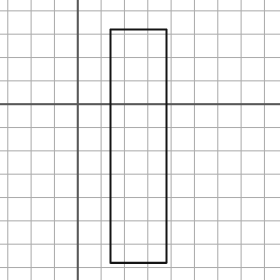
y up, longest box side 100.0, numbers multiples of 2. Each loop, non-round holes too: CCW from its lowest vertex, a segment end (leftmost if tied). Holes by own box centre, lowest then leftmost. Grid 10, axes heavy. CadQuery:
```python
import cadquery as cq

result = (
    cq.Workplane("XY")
    .moveTo(14.0, -68.0)
    .lineTo(38.0, -68.0)
    .lineTo(38.0, 32.0)
    .lineTo(14.0, 32.0)
    .close()
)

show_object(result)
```